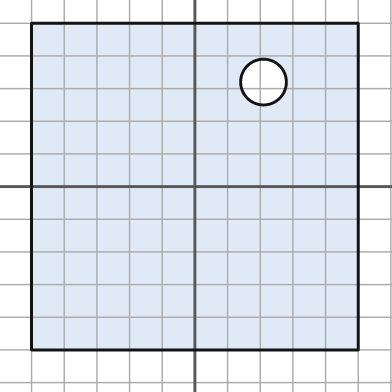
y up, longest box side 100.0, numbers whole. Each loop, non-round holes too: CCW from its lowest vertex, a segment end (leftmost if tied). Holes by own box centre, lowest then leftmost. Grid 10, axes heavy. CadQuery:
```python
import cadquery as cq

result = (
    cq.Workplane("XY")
    .moveTo(-50.0, -50.0)
    .lineTo(50.0, -50.0)
    .lineTo(50.0, 50.0)
    .lineTo(-50.0, 50.0)
    .close()
    .moveTo(21.0, 32.0)
    .circle(7.0)
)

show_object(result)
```